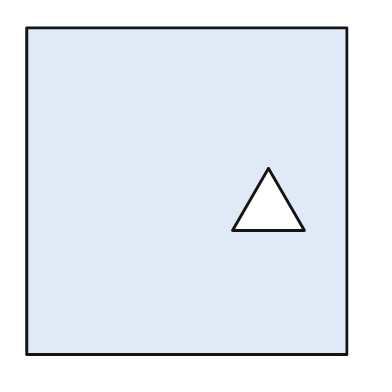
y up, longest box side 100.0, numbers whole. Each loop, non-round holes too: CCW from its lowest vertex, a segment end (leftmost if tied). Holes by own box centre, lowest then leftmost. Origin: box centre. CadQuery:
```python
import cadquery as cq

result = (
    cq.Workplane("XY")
    .moveTo(-49.0, -50.0)
    .lineTo(49.0, -50.0)
    .lineTo(49.0, 50.0)
    .lineTo(-49.0, 50.0)
    .close()
    .moveTo(14.0, -12.0)
    .lineTo(36.0, -12.0)
    .lineTo(25.0, 7.0)
    .close()
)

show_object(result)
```